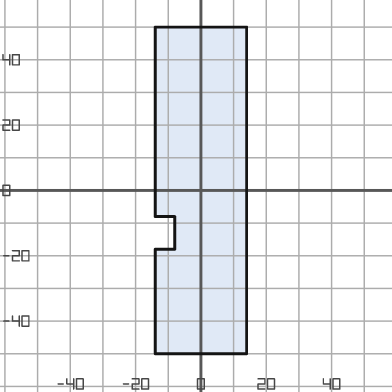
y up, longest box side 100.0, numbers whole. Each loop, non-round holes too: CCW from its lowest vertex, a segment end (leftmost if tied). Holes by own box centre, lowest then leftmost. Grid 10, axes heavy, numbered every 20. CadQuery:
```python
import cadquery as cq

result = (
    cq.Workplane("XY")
    .moveTo(-14.0, -50.0)
    .lineTo(14.0, -50.0)
    .lineTo(14.0, 50.0)
    .lineTo(-14.0, 50.0)
    .lineTo(-14.0, -8.0)
    .lineTo(-8.0, -8.0)
    .lineTo(-8.0, -18.0)
    .lineTo(-14.0, -18.0)
    .close()
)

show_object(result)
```